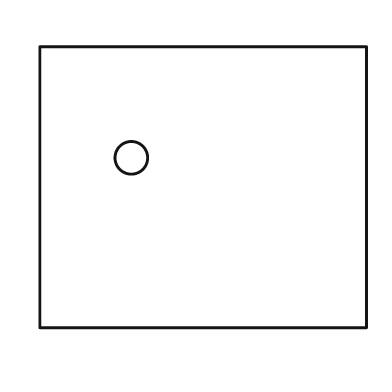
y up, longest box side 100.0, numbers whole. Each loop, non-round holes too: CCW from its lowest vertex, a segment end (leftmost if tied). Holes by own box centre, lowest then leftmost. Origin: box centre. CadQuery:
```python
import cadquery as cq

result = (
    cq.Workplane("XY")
    .moveTo(-50.0, -43.0)
    .lineTo(50.0, -43.0)
    .lineTo(50.0, 43.0)
    .lineTo(-50.0, 43.0)
    .close()
    .moveTo(-22.0, 9.0)
    .circle(5.0)
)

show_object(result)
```